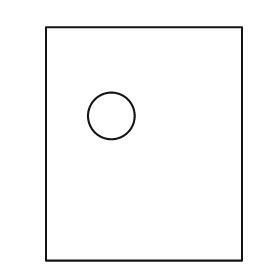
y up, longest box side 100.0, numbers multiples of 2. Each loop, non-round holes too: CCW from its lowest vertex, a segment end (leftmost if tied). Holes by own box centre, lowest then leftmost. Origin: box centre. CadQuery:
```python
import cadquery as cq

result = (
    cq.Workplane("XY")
    .moveTo(-42.0, -50.0)
    .lineTo(42.0, -50.0)
    .lineTo(42.0, 50.0)
    .lineTo(-42.0, 50.0)
    .close()
    .moveTo(-14.0, 12.0)
    .circle(10.0)
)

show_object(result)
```